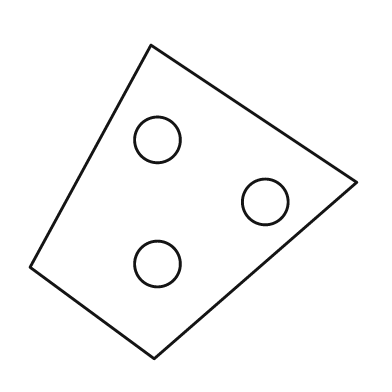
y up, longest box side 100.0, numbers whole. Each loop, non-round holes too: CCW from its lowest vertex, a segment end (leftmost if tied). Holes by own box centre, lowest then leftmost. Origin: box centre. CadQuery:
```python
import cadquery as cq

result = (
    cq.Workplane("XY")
    .moveTo(-12.0, -48.0)
    .lineTo(50.0, 6.0)
    .lineTo(-13.0, 48.0)
    .lineTo(-50.0, -20.0)
    .close()
    .moveTo(-11.0, -19.0)
    .circle(7.0)
    .moveTo(22.0, 0.0)
    .circle(7.0)
    .moveTo(-11.0, 19.0)
    .circle(7.0)
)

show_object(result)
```